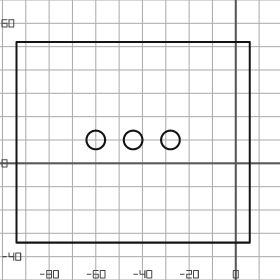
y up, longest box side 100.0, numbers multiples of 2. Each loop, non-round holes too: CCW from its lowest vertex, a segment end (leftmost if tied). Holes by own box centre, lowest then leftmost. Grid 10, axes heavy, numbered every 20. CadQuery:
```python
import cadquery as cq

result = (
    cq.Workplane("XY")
    .moveTo(-94.0, -34.0)
    .lineTo(6.0, -34.0)
    .lineTo(6.0, 52.0)
    .lineTo(-94.0, 52.0)
    .close()
    .moveTo(-60.0, 10.0)
    .circle(4.0)
    .moveTo(-44.0, 10.0)
    .circle(4.0)
    .moveTo(-28.0, 10.0)
    .circle(4.0)
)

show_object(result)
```